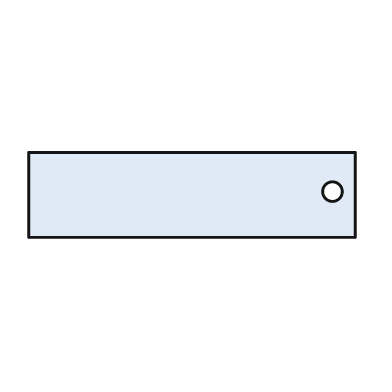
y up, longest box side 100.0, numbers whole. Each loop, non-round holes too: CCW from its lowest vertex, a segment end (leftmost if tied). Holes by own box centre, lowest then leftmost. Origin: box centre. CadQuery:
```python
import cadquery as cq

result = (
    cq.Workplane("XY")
    .moveTo(-50.0, -13.0)
    .lineTo(50.0, -13.0)
    .lineTo(50.0, 13.0)
    .lineTo(-50.0, 13.0)
    .close()
    .moveTo(43.0, 1.0)
    .circle(3.0)
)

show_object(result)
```